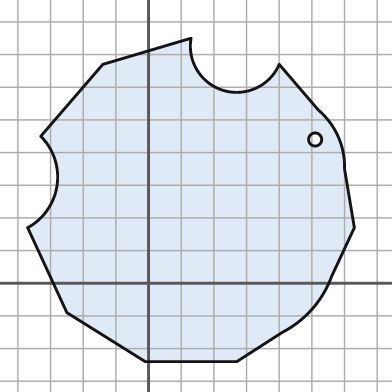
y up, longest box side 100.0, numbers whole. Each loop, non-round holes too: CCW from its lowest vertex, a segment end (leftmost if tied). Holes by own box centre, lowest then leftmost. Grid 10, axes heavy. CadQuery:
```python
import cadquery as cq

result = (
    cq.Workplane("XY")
    .moveTo(-1.0, -24.0)
    .lineTo(27.0, -24.0)
    .lineTo(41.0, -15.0)
    .threePointArc((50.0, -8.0), (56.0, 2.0))
    .lineTo(63.0, 17.0)
    .lineTo(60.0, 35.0)
    .threePointArc((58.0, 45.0), (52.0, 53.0))
    .lineTo(40.0, 67.0)
    .threePointArc((23.0, 59.0), (13.0, 75.0))
    .lineTo(-14.0, 67.0)
    .lineTo(-33.0, 45.0)
    .threePointArc((-28.0, 30.0), (-37.0, 17.0))
    .lineTo(-25.0, -9.0)
    .close()
    .moveTo(51.0, 44.0)
    .circle(2.0)
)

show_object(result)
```